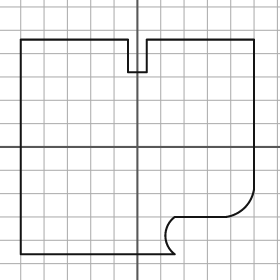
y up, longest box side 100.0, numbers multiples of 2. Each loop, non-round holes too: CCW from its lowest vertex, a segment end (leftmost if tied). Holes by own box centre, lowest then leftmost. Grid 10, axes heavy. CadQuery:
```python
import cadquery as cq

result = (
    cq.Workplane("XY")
    .moveTo(-50.0, -46.0)
    .lineTo(16.0, -46.0)
    .threePointArc((12.0, -38.0), (16.0, -30.0))
    .lineTo(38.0, -30.0)
    .threePointArc((46.0, -26.0), (50.0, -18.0))
    .lineTo(50.0, 46.0)
    .lineTo(4.0, 46.0)
    .lineTo(4.0, 32.0)
    .lineTo(-4.0, 32.0)
    .lineTo(-4.0, 46.0)
    .lineTo(-50.0, 46.0)
    .close()
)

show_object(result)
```